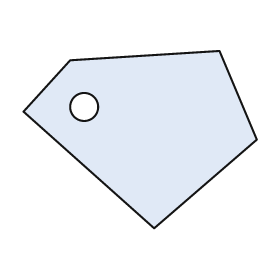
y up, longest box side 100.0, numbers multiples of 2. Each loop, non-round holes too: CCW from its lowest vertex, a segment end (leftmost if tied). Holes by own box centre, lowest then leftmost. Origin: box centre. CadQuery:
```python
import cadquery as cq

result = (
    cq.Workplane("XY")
    .moveTo(6.0, -38.0)
    .lineTo(50.0, 0.0)
    .lineTo(34.0, 38.0)
    .lineTo(-30.0, 34.0)
    .lineTo(-50.0, 12.0)
    .close()
    .moveTo(-24.0, 14.0)
    .circle(6.0)
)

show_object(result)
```